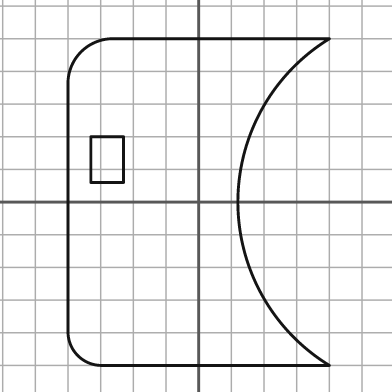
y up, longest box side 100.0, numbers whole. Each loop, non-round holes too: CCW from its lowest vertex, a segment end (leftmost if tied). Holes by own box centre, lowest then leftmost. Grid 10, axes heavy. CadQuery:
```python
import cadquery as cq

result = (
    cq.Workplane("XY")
    .moveTo(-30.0, -50.0)
    .lineTo(40.0, -50.0)
    .threePointArc((12.0, 0.0), (40.0, 50.0))
    .lineTo(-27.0, 50.0)
    .threePointArc((-36.0, 46.0), (-40.0, 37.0))
    .lineTo(-40.0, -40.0)
    .threePointArc((-37.0, -47.0), (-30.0, -50.0))
    .close()
    .moveTo(-33.0, 6.0)
    .lineTo(-23.0, 6.0)
    .lineTo(-23.0, 20.0)
    .lineTo(-33.0, 20.0)
    .close()
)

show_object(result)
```